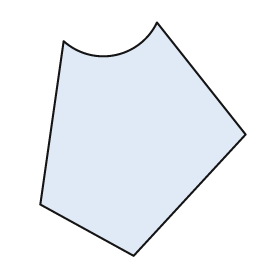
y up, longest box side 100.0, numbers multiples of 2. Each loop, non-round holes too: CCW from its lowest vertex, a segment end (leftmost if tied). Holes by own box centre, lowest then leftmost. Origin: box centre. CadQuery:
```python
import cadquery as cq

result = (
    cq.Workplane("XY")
    .moveTo(-4.0, -50.0)
    .lineTo(44.0, 2.0)
    .lineTo(6.0, 50.0)
    .threePointArc((-12.0, 36.0), (-34.0, 42.0))
    .lineTo(-44.0, -28.0)
    .close()
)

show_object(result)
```